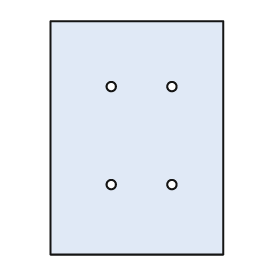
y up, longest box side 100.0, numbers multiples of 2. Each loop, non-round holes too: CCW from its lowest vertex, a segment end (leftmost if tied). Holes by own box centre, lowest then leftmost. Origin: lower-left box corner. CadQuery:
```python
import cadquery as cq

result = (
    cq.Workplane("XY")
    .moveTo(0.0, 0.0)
    .lineTo(74.0, 0.0)
    .lineTo(74.0, 100.0)
    .lineTo(0.0, 100.0)
    .close()
    .moveTo(26.0, 30.0)
    .circle(2.0)
    .moveTo(52.0, 30.0)
    .circle(2.0)
    .moveTo(26.0, 72.0)
    .circle(2.0)
    .moveTo(52.0, 72.0)
    .circle(2.0)
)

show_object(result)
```